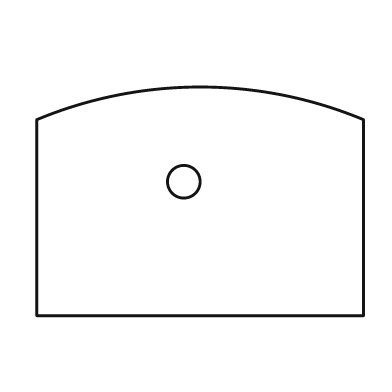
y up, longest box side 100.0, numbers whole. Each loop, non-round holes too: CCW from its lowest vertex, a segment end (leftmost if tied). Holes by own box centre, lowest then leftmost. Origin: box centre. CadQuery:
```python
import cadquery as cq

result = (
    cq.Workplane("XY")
    .moveTo(-50.0, -35.0)
    .lineTo(50.0, -35.0)
    .lineTo(50.0, 25.0)
    .threePointArc((0.0, 35.0), (-50.0, 25.0))
    .close()
    .moveTo(-5.0, 6.0)
    .circle(5.0)
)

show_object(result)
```